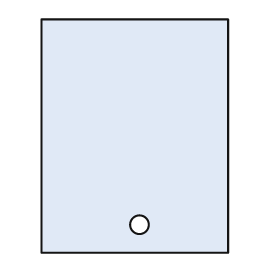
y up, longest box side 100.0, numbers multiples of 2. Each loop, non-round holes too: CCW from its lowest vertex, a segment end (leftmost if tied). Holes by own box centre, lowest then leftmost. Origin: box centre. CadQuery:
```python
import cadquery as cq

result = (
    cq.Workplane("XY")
    .moveTo(-40.0, -50.0)
    .lineTo(40.0, -50.0)
    .lineTo(40.0, 50.0)
    .lineTo(-40.0, 50.0)
    .close()
    .moveTo(2.0, -38.0)
    .circle(4.0)
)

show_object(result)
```